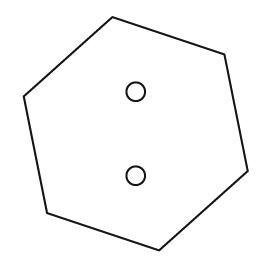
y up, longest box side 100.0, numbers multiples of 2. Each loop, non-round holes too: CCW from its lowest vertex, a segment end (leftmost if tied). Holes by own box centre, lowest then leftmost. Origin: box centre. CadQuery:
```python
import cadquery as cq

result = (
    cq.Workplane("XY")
    .moveTo(10.0, -50.0)
    .lineTo(48.0, -16.0)
    .lineTo(38.0, 34.0)
    .lineTo(-10.0, 50.0)
    .lineTo(-48.0, 16.0)
    .lineTo(-38.0, -34.0)
    .close()
    .moveTo(0.0, -18.0)
    .circle(4.0)
    .moveTo(0.0, 18.0)
    .circle(4.0)
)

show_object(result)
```